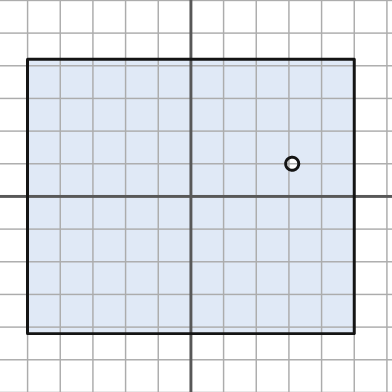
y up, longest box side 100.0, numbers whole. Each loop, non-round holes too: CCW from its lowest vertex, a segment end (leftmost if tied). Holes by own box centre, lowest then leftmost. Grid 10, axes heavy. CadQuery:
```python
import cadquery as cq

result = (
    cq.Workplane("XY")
    .moveTo(-50.0, -42.0)
    .lineTo(50.0, -42.0)
    .lineTo(50.0, 42.0)
    .lineTo(-50.0, 42.0)
    .close()
    .moveTo(31.0, 10.0)
    .circle(2.0)
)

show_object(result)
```